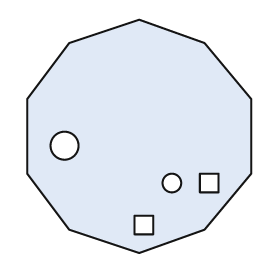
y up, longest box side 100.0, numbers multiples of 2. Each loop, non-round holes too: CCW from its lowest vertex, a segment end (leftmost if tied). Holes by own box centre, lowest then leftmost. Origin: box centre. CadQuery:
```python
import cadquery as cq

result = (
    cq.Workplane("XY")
    .moveTo(0.0, -50.0)
    .lineTo(28.0, -40.0)
    .lineTo(48.0, -16.0)
    .lineTo(48.0, 16.0)
    .lineTo(28.0, 40.0)
    .lineTo(0.0, 50.0)
    .lineTo(-30.0, 40.0)
    .lineTo(-48.0, 16.0)
    .lineTo(-48.0, -16.0)
    .lineTo(-30.0, -40.0)
    .close()
    .moveTo(-2.0, -42.0)
    .lineTo(6.0, -42.0)
    .lineTo(6.0, -34.0)
    .lineTo(-2.0, -34.0)
    .close()
    .moveTo(14.0, -20.0)
    .circle(4.0)
    .moveTo(26.0, -24.0)
    .lineTo(34.0, -24.0)
    .lineTo(34.0, -16.0)
    .lineTo(26.0, -16.0)
    .close()
    .moveTo(-32.0, -4.0)
    .circle(6.0)
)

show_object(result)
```